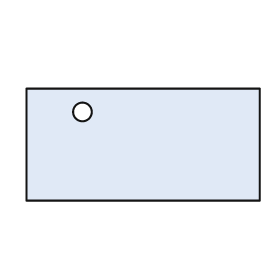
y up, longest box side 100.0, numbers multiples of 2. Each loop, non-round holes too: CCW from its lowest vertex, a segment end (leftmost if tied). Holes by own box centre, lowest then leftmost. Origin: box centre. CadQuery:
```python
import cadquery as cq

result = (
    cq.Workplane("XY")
    .moveTo(-50.0, -24.0)
    .lineTo(50.0, -24.0)
    .lineTo(50.0, 24.0)
    .lineTo(-50.0, 24.0)
    .close()
    .moveTo(-26.0, 14.0)
    .circle(4.0)
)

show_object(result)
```